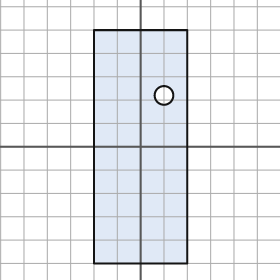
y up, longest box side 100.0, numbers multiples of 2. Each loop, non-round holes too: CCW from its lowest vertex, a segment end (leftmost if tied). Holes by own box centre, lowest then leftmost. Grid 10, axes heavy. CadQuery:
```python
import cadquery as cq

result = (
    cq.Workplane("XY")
    .moveTo(-20.0, -50.0)
    .lineTo(20.0, -50.0)
    .lineTo(20.0, 50.0)
    .lineTo(-20.0, 50.0)
    .close()
    .moveTo(10.0, 22.0)
    .circle(4.0)
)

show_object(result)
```